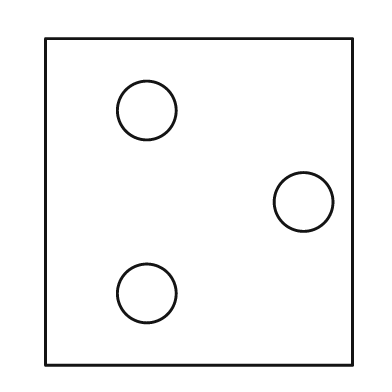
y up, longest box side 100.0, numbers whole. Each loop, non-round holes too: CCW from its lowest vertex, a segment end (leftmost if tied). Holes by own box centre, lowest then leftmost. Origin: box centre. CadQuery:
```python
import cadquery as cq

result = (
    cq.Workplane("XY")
    .moveTo(-47.0, -50.0)
    .lineTo(47.0, -50.0)
    .lineTo(47.0, 50.0)
    .lineTo(-47.0, 50.0)
    .close()
    .moveTo(-16.0, -28.0)
    .circle(9.0)
    .moveTo(32.0, 0.0)
    .circle(9.0)
    .moveTo(-16.0, 28.0)
    .circle(9.0)
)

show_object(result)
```